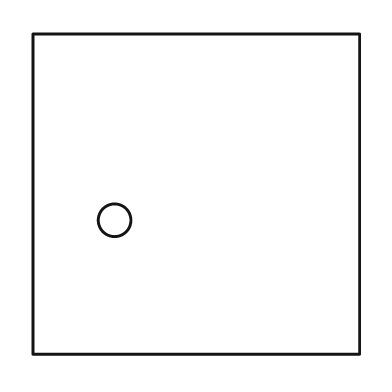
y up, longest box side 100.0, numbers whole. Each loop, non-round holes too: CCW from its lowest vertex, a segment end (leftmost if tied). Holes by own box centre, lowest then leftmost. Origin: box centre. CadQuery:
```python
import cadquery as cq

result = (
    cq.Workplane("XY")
    .moveTo(-50.0, -49.0)
    .lineTo(50.0, -49.0)
    .lineTo(50.0, 49.0)
    .lineTo(-50.0, 49.0)
    .close()
    .moveTo(-25.0, -8.0)
    .circle(5.0)
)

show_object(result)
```